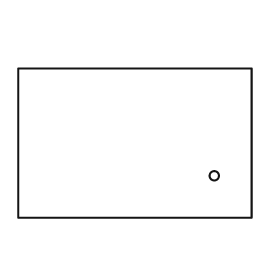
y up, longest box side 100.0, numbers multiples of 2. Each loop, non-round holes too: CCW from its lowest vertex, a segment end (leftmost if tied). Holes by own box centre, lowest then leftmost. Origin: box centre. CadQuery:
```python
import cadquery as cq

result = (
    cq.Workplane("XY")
    .moveTo(-50.0, -32.0)
    .lineTo(50.0, -32.0)
    .lineTo(50.0, 32.0)
    .lineTo(-50.0, 32.0)
    .close()
    .moveTo(34.0, -14.0)
    .circle(2.0)
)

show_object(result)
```